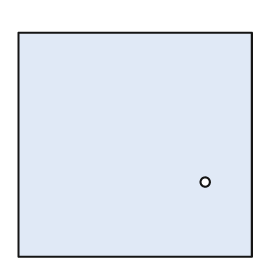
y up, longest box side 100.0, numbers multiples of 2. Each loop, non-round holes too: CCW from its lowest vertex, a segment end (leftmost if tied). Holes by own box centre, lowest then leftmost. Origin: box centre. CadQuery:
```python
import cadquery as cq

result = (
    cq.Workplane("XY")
    .moveTo(-50.0, -48.0)
    .lineTo(50.0, -48.0)
    .lineTo(50.0, 48.0)
    .lineTo(-50.0, 48.0)
    .close()
    .moveTo(30.0, -16.0)
    .circle(2.0)
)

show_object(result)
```